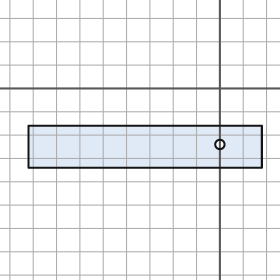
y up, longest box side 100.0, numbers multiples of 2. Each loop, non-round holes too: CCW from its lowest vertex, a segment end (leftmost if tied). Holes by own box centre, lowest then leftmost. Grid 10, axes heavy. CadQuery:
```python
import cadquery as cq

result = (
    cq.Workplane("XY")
    .moveTo(-82.0, -34.0)
    .lineTo(18.0, -34.0)
    .lineTo(18.0, -16.0)
    .lineTo(-82.0, -16.0)
    .close()
    .moveTo(0.0, -24.0)
    .circle(2.0)
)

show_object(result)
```